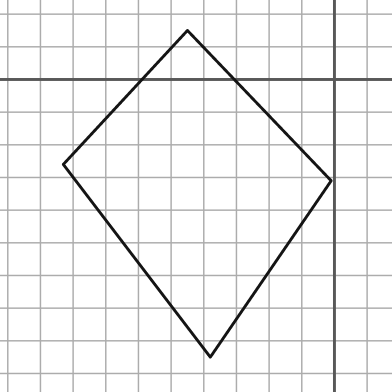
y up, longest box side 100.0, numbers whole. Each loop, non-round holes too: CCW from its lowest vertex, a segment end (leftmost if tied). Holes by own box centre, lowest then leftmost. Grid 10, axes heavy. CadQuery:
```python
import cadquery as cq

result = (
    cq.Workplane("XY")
    .moveTo(-38.0, -85.0)
    .lineTo(-1.0, -31.0)
    .lineTo(-45.0, 15.0)
    .lineTo(-83.0, -26.0)
    .close()
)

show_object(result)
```